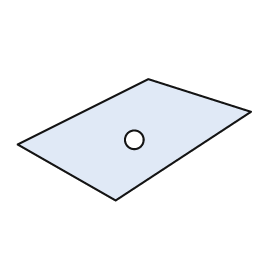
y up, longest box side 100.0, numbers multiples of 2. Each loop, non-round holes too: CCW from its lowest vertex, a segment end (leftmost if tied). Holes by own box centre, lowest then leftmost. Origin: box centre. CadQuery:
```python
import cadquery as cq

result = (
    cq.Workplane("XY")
    .moveTo(-8.0, -26.0)
    .lineTo(50.0, 12.0)
    .lineTo(6.0, 26.0)
    .lineTo(-50.0, -2.0)
    .close()
    .moveTo(0.0, 0.0)
    .circle(4.0)
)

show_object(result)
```